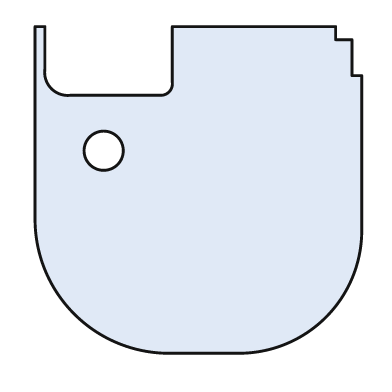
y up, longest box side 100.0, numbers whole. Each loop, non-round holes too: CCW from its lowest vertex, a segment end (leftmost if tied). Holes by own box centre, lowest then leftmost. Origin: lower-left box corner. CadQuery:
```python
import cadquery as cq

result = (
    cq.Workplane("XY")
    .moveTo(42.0, 0.0)
    .lineTo(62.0, 0.0)
    .threePointArc((89.0, 11.0), (100.0, 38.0))
    .lineTo(100.0, 85.0)
    .lineTo(97.0, 85.0)
    .lineTo(97.0, 96.0)
    .lineTo(92.0, 96.0)
    .lineTo(92.0, 100.0)
    .lineTo(42.0, 100.0)
    .lineTo(42.0, 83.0)
    .threePointArc((41.0, 80.0), (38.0, 79.0))
    .lineTo(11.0, 79.0)
    .threePointArc((5.0, 81.0), (3.0, 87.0))
    .lineTo(3.0, 100.0)
    .lineTo(0.0, 100.0)
    .lineTo(0.0, 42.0)
    .threePointArc((12.0, 12.0), (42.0, 0.0))
    .close()
    .moveTo(21.0, 62.0)
    .circle(6.0)
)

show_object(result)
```